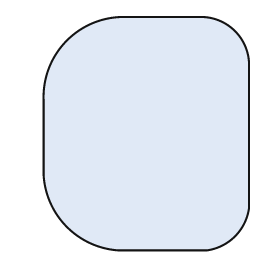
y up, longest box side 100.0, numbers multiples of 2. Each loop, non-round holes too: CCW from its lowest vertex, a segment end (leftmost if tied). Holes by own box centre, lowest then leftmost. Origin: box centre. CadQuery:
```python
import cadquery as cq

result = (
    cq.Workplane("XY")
    .moveTo(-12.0, -50.0)
    .lineTo(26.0, -50.0)
    .threePointArc((38.0, -44.0), (44.0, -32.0))
    .lineTo(44.0, 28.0)
    .threePointArc((38.0, 44.0), (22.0, 50.0))
    .lineTo(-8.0, 50.0)
    .threePointArc((-34.0, 40.0), (-44.0, 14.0))
    .lineTo(-44.0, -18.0)
    .threePointArc((-34.0, -40.0), (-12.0, -50.0))
    .close()
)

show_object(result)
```